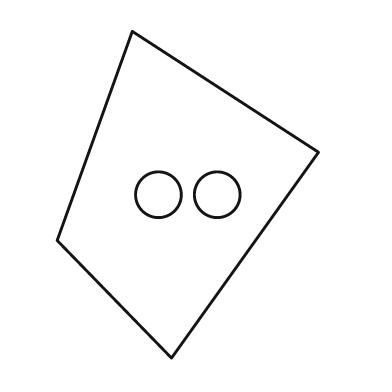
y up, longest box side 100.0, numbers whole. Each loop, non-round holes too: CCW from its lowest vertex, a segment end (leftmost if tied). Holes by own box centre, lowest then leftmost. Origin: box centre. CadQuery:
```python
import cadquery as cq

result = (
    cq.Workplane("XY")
    .moveTo(-5.0, -50.0)
    .lineTo(40.0, 13.0)
    .lineTo(-17.0, 50.0)
    .lineTo(-40.0, -14.0)
    .close()
    .moveTo(-9.0, 0.0)
    .circle(7.0)
    .moveTo(9.0, 0.0)
    .circle(7.0)
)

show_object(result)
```